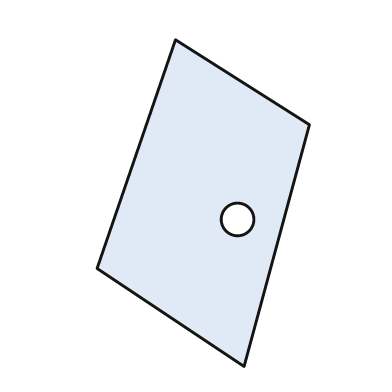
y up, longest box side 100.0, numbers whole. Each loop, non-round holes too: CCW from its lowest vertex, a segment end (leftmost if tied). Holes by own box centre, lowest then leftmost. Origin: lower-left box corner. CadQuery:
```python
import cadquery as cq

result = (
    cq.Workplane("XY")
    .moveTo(45.0, 0.0)
    .lineTo(65.0, 74.0)
    .lineTo(24.0, 100.0)
    .lineTo(0.0, 30.0)
    .close()
    .moveTo(43.0, 45.0)
    .circle(5.0)
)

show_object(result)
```